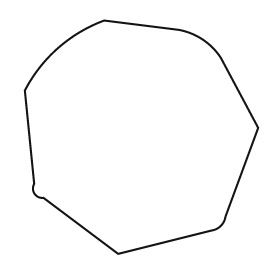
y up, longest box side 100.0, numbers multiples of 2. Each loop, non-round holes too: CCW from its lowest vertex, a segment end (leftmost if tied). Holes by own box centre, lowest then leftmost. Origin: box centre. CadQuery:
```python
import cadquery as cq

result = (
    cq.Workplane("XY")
    .moveTo(-10.0, -50.0)
    .lineTo(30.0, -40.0)
    .threePointArc((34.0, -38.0), (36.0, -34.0))
    .lineTo(50.0, 4.0)
    .lineTo(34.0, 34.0)
    .threePointArc((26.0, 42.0), (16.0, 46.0))
    .lineTo(-16.0, 50.0)
    .threePointArc((-36.0, 38.0), (-50.0, 20.0))
    .lineTo(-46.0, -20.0)
    .threePointArc((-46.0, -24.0), (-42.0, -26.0))
    .close()
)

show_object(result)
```